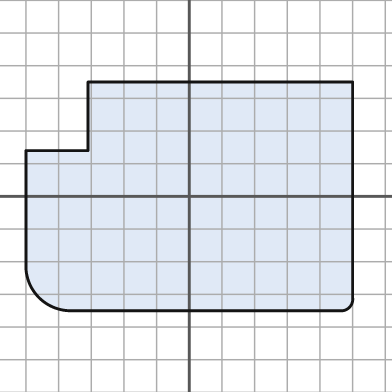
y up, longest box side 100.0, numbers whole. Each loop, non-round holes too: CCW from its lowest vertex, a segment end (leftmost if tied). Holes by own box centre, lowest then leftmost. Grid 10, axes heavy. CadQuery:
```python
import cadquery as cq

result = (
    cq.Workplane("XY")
    .moveTo(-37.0, -35.0)
    .lineTo(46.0, -35.0)
    .threePointArc((49.0, -34.0), (50.0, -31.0))
    .lineTo(50.0, 35.0)
    .lineTo(-31.0, 35.0)
    .lineTo(-31.0, 14.0)
    .lineTo(-50.0, 14.0)
    .lineTo(-50.0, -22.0)
    .threePointArc((-46.0, -31.0), (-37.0, -35.0))
    .close()
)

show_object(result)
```